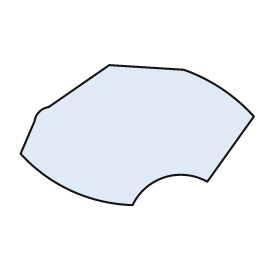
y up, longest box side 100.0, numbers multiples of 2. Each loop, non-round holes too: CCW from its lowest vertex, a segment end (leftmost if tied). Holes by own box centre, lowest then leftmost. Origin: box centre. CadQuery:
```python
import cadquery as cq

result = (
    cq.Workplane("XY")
    .moveTo(-2.0, -30.0)
    .threePointArc((12.0, -18.0), (30.0, -20.0))
    .lineTo(50.0, 8.0)
    .threePointArc((36.0, 20.0), (20.0, 28.0))
    .lineTo(-12.0, 30.0)
    .lineTo(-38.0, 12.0)
    .threePointArc((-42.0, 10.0), (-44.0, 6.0))
    .lineTo(-50.0, -8.0)
    .threePointArc((-28.0, -24.0), (-2.0, -30.0))
    .close()
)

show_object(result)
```